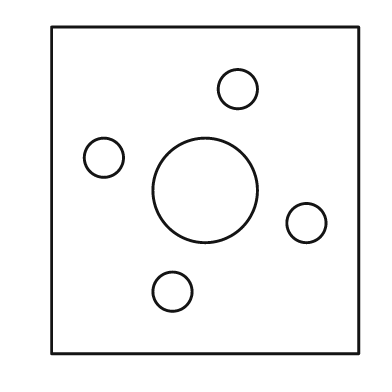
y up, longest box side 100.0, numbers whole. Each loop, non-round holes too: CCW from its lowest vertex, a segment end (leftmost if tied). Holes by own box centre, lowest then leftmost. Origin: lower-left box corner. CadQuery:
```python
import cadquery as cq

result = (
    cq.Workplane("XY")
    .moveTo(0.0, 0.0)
    .lineTo(94.0, 0.0)
    .lineTo(94.0, 100.0)
    .lineTo(0.0, 100.0)
    .close()
    .moveTo(37.0, 19.0)
    .circle(6.0)
    .moveTo(78.0, 40.0)
    .circle(6.0)
    .moveTo(47.0, 50.0)
    .circle(16.0)
    .moveTo(16.0, 60.0)
    .circle(6.0)
    .moveTo(57.0, 81.0)
    .circle(6.0)
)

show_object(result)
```